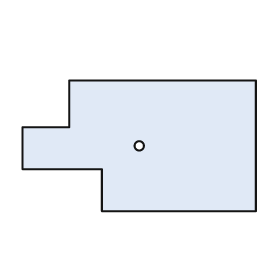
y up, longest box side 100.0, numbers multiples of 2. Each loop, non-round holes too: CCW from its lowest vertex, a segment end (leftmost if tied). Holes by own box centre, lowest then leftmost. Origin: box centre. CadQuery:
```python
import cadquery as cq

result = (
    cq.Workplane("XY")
    .moveTo(-16.0, -28.0)
    .lineTo(50.0, -28.0)
    .lineTo(50.0, 28.0)
    .lineTo(-30.0, 28.0)
    .lineTo(-30.0, 8.0)
    .lineTo(-50.0, 8.0)
    .lineTo(-50.0, -10.0)
    .lineTo(-16.0, -10.0)
    .close()
    .moveTo(0.0, 0.0)
    .circle(2.0)
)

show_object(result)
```